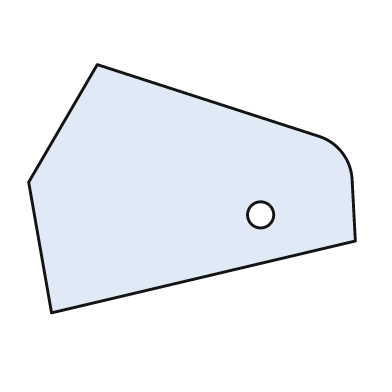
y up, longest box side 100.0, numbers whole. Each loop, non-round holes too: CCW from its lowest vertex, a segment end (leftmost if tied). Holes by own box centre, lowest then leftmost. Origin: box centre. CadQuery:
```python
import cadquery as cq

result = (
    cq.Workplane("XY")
    .moveTo(-43.0, -38.0)
    .lineTo(50.0, -16.0)
    .lineTo(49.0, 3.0)
    .threePointArc((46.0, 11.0), (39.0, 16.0))
    .lineTo(-29.0, 38.0)
    .lineTo(-50.0, 2.0)
    .close()
    .moveTo(21.0, -8.0)
    .circle(4.0)
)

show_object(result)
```